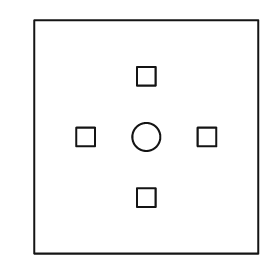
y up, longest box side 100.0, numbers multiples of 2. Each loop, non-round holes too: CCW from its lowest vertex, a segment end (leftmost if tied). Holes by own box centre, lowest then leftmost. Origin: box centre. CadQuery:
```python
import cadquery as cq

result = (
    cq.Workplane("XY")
    .moveTo(-48.0, -50.0)
    .lineTo(48.0, -50.0)
    .lineTo(48.0, 50.0)
    .lineTo(-48.0, 50.0)
    .close()
    .moveTo(-4.0, -30.0)
    .lineTo(4.0, -30.0)
    .lineTo(4.0, -22.0)
    .lineTo(-4.0, -22.0)
    .close()
    .moveTo(-30.0, -4.0)
    .lineTo(-22.0, -4.0)
    .lineTo(-22.0, 4.0)
    .lineTo(-30.0, 4.0)
    .close()
    .moveTo(0.0, 0.0)
    .circle(6.0)
    .moveTo(22.0, -4.0)
    .lineTo(30.0, -4.0)
    .lineTo(30.0, 4.0)
    .lineTo(22.0, 4.0)
    .close()
    .moveTo(-4.0, 22.0)
    .lineTo(4.0, 22.0)
    .lineTo(4.0, 30.0)
    .lineTo(-4.0, 30.0)
    .close()
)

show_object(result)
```